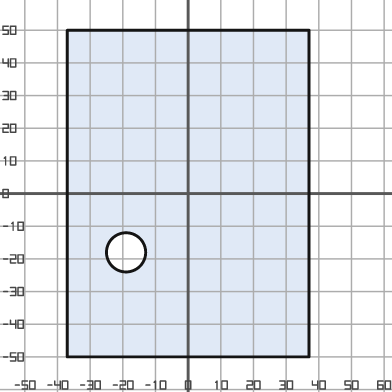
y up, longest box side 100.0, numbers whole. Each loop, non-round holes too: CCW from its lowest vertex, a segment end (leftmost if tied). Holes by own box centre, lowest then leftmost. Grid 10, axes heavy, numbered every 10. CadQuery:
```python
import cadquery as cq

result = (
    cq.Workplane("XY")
    .moveTo(-37.0, -50.0)
    .lineTo(37.0, -50.0)
    .lineTo(37.0, 50.0)
    .lineTo(-37.0, 50.0)
    .close()
    .moveTo(-19.0, -18.0)
    .circle(6.0)
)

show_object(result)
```